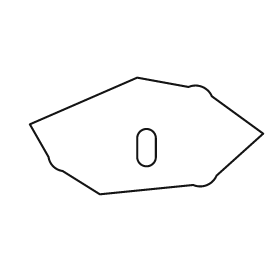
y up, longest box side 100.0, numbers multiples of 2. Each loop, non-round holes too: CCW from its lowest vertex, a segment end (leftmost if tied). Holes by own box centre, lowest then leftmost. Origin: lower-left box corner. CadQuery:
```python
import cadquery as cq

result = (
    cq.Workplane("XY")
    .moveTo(30.0, 0.0)
    .lineTo(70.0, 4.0)
    .threePointArc((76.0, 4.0), (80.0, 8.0))
    .lineTo(100.0, 26.0)
    .lineTo(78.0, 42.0)
    .threePointArc((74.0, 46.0), (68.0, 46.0))
    .lineTo(46.0, 50.0)
    .lineTo(0.0, 30.0)
    .lineTo(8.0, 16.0)
    .threePointArc((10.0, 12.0), (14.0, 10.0))
    .close()
    .moveTo(46.0, 16.0)
    .threePointArc((50.0, 12.0), (54.0, 16.0))
    .lineTo(54.0, 24.0)
    .threePointArc((50.0, 28.0), (46.0, 24.0))
    .close()
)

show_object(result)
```